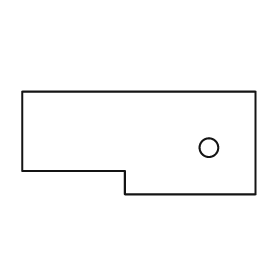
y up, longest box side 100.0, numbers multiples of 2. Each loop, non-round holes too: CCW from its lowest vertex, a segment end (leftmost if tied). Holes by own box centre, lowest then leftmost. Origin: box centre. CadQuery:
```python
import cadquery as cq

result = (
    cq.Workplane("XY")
    .moveTo(-6.0, -22.0)
    .lineTo(50.0, -22.0)
    .lineTo(50.0, 22.0)
    .lineTo(-50.0, 22.0)
    .lineTo(-50.0, -12.0)
    .lineTo(-6.0, -12.0)
    .close()
    .moveTo(30.0, -2.0)
    .circle(4.0)
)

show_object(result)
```